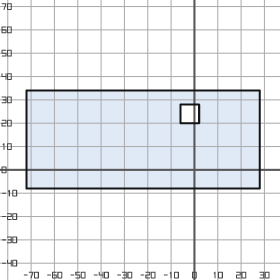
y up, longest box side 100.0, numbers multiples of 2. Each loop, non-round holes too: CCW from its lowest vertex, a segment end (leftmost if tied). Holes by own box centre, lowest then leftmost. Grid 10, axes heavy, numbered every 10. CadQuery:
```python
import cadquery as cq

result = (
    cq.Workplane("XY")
    .moveTo(-72.0, -8.0)
    .lineTo(28.0, -8.0)
    .lineTo(28.0, 34.0)
    .lineTo(-72.0, 34.0)
    .close()
    .moveTo(-6.0, 20.0)
    .lineTo(2.0, 20.0)
    .lineTo(2.0, 28.0)
    .lineTo(-6.0, 28.0)
    .close()
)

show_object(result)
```